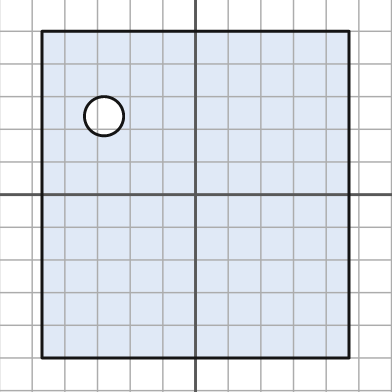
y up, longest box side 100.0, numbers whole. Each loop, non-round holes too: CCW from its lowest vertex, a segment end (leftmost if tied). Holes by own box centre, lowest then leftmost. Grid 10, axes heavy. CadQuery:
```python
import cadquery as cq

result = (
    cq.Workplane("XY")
    .moveTo(-47.0, -50.0)
    .lineTo(47.0, -50.0)
    .lineTo(47.0, 50.0)
    .lineTo(-47.0, 50.0)
    .close()
    .moveTo(-28.0, 24.0)
    .circle(6.0)
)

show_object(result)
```